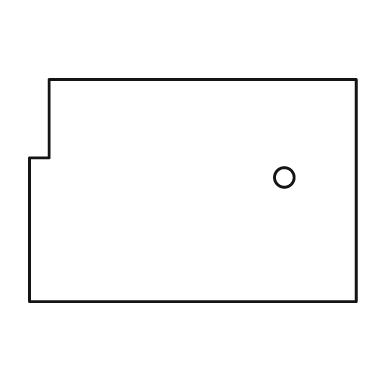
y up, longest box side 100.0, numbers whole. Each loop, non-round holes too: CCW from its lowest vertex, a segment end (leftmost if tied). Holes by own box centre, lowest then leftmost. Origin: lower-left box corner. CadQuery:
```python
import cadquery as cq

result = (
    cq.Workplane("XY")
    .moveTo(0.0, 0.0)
    .lineTo(100.0, 0.0)
    .lineTo(100.0, 68.0)
    .lineTo(6.0, 68.0)
    .lineTo(6.0, 44.0)
    .lineTo(0.0, 44.0)
    .close()
    .moveTo(78.0, 38.0)
    .circle(3.0)
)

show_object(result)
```